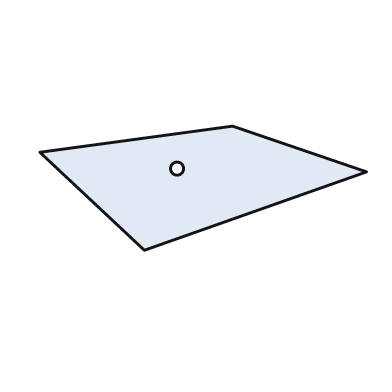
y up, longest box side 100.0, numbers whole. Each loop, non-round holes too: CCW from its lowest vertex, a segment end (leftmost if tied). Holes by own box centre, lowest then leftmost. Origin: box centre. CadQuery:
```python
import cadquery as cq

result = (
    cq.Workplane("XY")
    .moveTo(-18.0, -19.0)
    .lineTo(50.0, 5.0)
    .lineTo(9.0, 19.0)
    .lineTo(-50.0, 11.0)
    .close()
    .moveTo(-8.0, 6.0)
    .circle(2.0)
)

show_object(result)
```